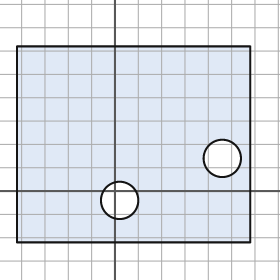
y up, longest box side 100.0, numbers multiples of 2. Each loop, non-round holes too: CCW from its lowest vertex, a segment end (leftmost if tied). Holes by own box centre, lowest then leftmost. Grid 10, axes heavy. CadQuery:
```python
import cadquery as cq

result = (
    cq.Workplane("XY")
    .moveTo(-42.0, -22.0)
    .lineTo(58.0, -22.0)
    .lineTo(58.0, 62.0)
    .lineTo(-42.0, 62.0)
    .close()
    .moveTo(2.0, -4.0)
    .circle(8.0)
    .moveTo(46.0, 14.0)
    .circle(8.0)
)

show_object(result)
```